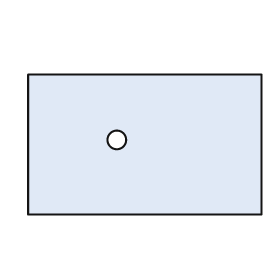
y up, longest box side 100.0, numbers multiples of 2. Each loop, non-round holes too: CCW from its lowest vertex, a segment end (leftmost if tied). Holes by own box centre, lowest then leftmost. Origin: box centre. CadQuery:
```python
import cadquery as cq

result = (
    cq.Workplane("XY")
    .moveTo(-50.0, -30.0)
    .lineTo(50.0, -30.0)
    .lineTo(50.0, 30.0)
    .lineTo(-50.0, 30.0)
    .close()
    .moveTo(-12.0, 2.0)
    .circle(4.0)
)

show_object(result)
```